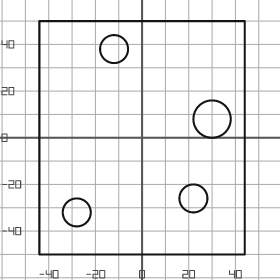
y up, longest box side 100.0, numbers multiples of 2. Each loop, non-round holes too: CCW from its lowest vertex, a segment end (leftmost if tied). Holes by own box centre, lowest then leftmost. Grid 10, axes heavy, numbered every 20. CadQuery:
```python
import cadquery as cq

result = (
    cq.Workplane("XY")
    .moveTo(-44.0, -50.0)
    .lineTo(44.0, -50.0)
    .lineTo(44.0, 50.0)
    .lineTo(-44.0, 50.0)
    .close()
    .moveTo(-28.0, -32.0)
    .circle(6.0)
    .moveTo(22.0, -26.0)
    .circle(6.0)
    .moveTo(30.0, 8.0)
    .circle(8.0)
    .moveTo(-12.0, 38.0)
    .circle(6.0)
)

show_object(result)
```